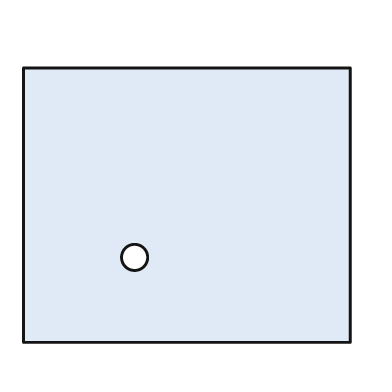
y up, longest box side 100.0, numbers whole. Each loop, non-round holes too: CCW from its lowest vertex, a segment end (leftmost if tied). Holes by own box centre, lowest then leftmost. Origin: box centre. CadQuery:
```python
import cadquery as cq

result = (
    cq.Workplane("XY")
    .moveTo(-50.0, -42.0)
    .lineTo(50.0, -42.0)
    .lineTo(50.0, 42.0)
    .lineTo(-50.0, 42.0)
    .close()
    .moveTo(-16.0, -16.0)
    .circle(4.0)
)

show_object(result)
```